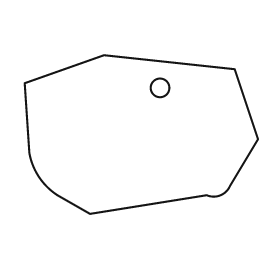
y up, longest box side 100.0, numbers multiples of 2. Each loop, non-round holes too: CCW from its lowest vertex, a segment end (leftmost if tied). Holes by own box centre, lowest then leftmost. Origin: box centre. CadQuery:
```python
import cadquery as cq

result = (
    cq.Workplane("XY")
    .moveTo(-22.0, -34.0)
    .lineTo(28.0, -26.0)
    .threePointArc((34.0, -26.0), (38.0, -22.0))
    .lineTo(50.0, -2.0)
    .lineTo(40.0, 28.0)
    .lineTo(-16.0, 34.0)
    .lineTo(-50.0, 22.0)
    .lineTo(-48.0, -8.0)
    .threePointArc((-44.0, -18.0), (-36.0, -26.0))
    .close()
    .moveTo(8.0, 20.0)
    .circle(4.0)
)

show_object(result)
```